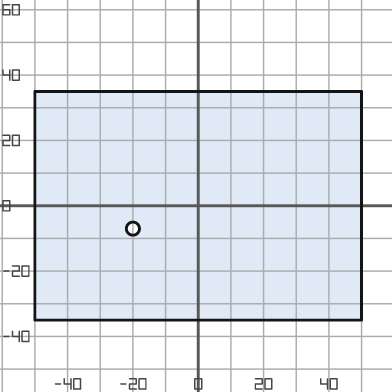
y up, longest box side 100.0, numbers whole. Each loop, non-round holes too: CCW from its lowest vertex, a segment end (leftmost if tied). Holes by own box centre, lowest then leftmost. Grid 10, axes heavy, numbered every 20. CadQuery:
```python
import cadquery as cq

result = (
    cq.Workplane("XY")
    .moveTo(-50.0, -35.0)
    .lineTo(50.0, -35.0)
    .lineTo(50.0, 35.0)
    .lineTo(-50.0, 35.0)
    .close()
    .moveTo(-20.0, -7.0)
    .circle(2.0)
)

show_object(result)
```